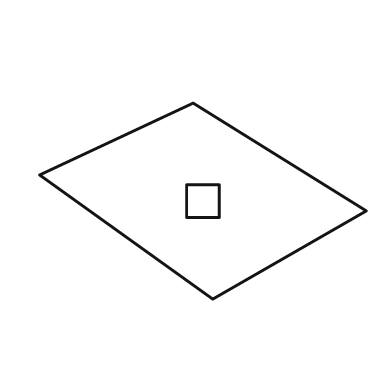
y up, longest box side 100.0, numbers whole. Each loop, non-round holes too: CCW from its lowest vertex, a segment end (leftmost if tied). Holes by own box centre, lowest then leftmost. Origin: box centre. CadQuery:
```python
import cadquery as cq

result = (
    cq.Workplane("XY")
    .moveTo(3.0, -30.0)
    .lineTo(50.0, -3.0)
    .lineTo(-3.0, 30.0)
    .lineTo(-50.0, 8.0)
    .close()
    .moveTo(-5.0, -5.0)
    .lineTo(5.0, -5.0)
    .lineTo(5.0, 5.0)
    .lineTo(-5.0, 5.0)
    .close()
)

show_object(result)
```